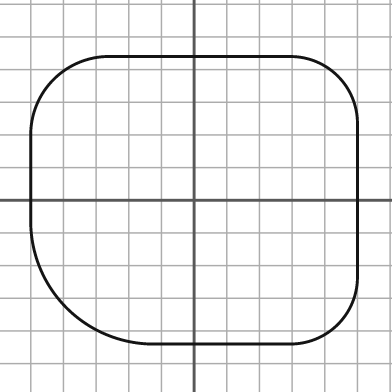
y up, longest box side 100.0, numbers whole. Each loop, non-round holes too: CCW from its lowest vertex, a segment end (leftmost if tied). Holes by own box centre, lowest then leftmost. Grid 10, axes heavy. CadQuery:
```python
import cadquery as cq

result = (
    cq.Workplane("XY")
    .moveTo(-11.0, -44.0)
    .lineTo(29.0, -44.0)
    .threePointArc((44.0, -38.0), (50.0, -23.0))
    .lineTo(50.0, 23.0)
    .threePointArc((44.0, 38.0), (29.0, 44.0))
    .lineTo(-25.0, 44.0)
    .threePointArc((-43.0, 37.0), (-50.0, 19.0))
    .lineTo(-50.0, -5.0)
    .threePointArc((-39.0, -33.0), (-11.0, -44.0))
    .close()
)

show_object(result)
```